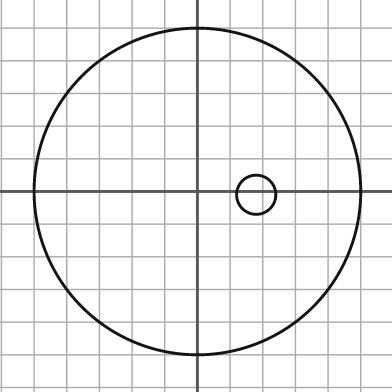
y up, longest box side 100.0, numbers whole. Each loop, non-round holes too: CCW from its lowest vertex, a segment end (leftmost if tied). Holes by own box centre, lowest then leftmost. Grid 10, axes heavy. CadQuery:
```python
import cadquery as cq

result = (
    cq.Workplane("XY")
    .moveTo(0.0, 0.0)
    .circle(50.0)
    .moveTo(18.0, -1.0)
    .circle(6.0)
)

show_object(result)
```